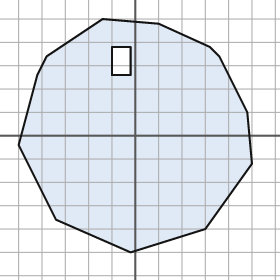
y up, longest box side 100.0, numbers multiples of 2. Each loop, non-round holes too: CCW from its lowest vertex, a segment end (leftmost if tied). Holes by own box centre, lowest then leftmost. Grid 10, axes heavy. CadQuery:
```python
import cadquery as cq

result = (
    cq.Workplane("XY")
    .moveTo(-2.0, -50.0)
    .lineTo(30.0, -40.0)
    .lineTo(50.0, -12.0)
    .lineTo(48.0, 10.0)
    .lineTo(36.0, 34.0)
    .lineTo(32.0, 38.0)
    .lineTo(10.0, 48.0)
    .lineTo(-14.0, 50.0)
    .lineTo(-38.0, 34.0)
    .lineTo(-42.0, 26.0)
    .lineTo(-50.0, -4.0)
    .lineTo(-34.0, -36.0)
    .close()
    .moveTo(-10.0, 26.0)
    .lineTo(-2.0, 26.0)
    .lineTo(-2.0, 38.0)
    .lineTo(-10.0, 38.0)
    .close()
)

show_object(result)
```